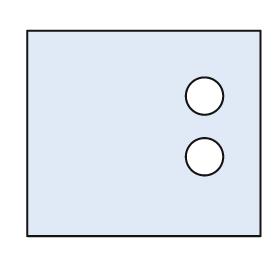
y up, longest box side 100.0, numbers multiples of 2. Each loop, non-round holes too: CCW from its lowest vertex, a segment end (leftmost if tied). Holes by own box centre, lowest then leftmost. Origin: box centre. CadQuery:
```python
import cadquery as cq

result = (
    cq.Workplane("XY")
    .moveTo(-50.0, -44.0)
    .lineTo(50.0, -44.0)
    .lineTo(50.0, 44.0)
    .lineTo(-50.0, 44.0)
    .close()
    .moveTo(26.0, -10.0)
    .circle(8.0)
    .moveTo(26.0, 16.0)
    .circle(8.0)
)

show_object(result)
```